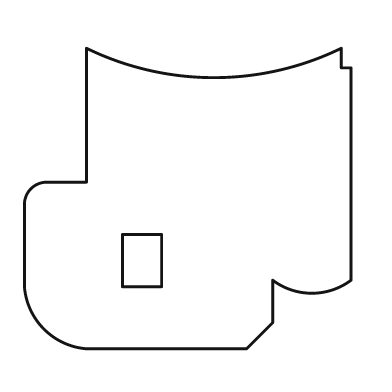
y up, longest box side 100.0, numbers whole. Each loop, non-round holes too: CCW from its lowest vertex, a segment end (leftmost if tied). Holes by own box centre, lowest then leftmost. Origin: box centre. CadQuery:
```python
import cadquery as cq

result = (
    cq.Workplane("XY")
    .moveTo(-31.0, -46.0)
    .lineTo(18.0, -46.0)
    .lineTo(26.0, -38.0)
    .lineTo(26.0, -25.0)
    .threePointArc((38.0, -29.0), (50.0, -25.0))
    .lineTo(50.0, 40.0)
    .lineTo(47.0, 40.0)
    .lineTo(47.0, 46.0)
    .threePointArc((8.0, 37.0), (-31.0, 46.0))
    .lineTo(-31.0, 5.0)
    .lineTo(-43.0, 5.0)
    .threePointArc((-48.0, 3.0), (-50.0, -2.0))
    .lineTo(-50.0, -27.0)
    .threePointArc((-44.0, -40.0), (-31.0, -46.0))
    .close()
    .moveTo(-20.0, -27.0)
    .lineTo(-8.0, -27.0)
    .lineTo(-8.0, -11.0)
    .lineTo(-20.0, -11.0)
    .close()
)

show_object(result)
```